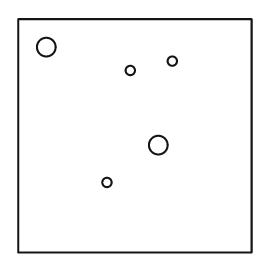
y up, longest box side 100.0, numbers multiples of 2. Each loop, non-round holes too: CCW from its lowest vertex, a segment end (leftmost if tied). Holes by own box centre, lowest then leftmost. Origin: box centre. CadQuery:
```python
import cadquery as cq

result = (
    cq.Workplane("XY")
    .moveTo(-50.0, -50.0)
    .lineTo(50.0, -50.0)
    .lineTo(50.0, 50.0)
    .lineTo(-50.0, 50.0)
    .close()
    .moveTo(-12.0, -20.0)
    .circle(2.0)
    .moveTo(10.0, -4.0)
    .circle(4.0)
    .moveTo(-2.0, 28.0)
    .circle(2.0)
    .moveTo(16.0, 32.0)
    .circle(2.0)
    .moveTo(-38.0, 38.0)
    .circle(4.0)
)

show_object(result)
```